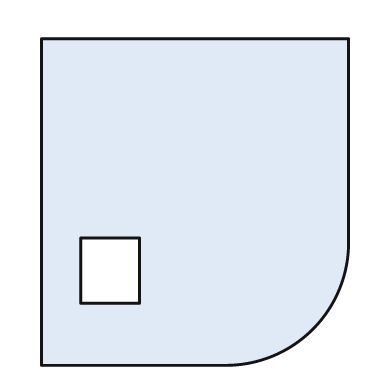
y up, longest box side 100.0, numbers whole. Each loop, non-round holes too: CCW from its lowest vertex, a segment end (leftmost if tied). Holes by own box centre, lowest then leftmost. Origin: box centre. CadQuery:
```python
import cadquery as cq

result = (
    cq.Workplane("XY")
    .moveTo(-47.0, -50.0)
    .lineTo(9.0, -50.0)
    .threePointArc((36.0, -39.0), (47.0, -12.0))
    .lineTo(47.0, 50.0)
    .lineTo(-47.0, 50.0)
    .close()
    .moveTo(-35.0, -31.0)
    .lineTo(-17.0, -31.0)
    .lineTo(-17.0, -11.0)
    .lineTo(-35.0, -11.0)
    .close()
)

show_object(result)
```